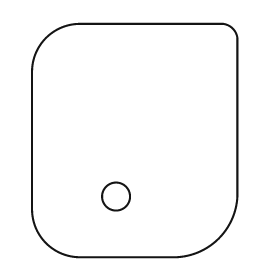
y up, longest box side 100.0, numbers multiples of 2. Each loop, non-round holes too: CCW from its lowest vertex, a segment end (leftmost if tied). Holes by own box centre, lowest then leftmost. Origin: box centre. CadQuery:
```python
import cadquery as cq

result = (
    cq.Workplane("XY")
    .moveTo(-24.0, -50.0)
    .lineTo(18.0, -50.0)
    .threePointArc((36.0, -42.0), (44.0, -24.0))
    .lineTo(44.0, 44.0)
    .threePointArc((42.0, 48.0), (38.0, 50.0))
    .lineTo(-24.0, 50.0)
    .threePointArc((-38.0, 44.0), (-44.0, 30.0))
    .lineTo(-44.0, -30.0)
    .threePointArc((-38.0, -44.0), (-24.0, -50.0))
    .close()
    .moveTo(-8.0, -24.0)
    .circle(6.0)
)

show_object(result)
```